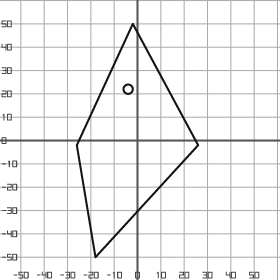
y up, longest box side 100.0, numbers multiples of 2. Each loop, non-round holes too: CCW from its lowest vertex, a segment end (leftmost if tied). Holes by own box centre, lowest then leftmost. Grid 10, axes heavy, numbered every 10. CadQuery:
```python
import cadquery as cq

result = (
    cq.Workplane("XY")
    .moveTo(-18.0, -50.0)
    .lineTo(26.0, -2.0)
    .lineTo(-2.0, 50.0)
    .lineTo(-26.0, -2.0)
    .close()
    .moveTo(-4.0, 22.0)
    .circle(2.0)
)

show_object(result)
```